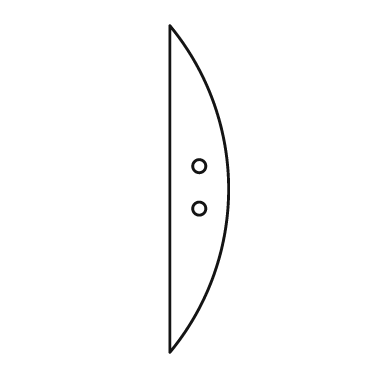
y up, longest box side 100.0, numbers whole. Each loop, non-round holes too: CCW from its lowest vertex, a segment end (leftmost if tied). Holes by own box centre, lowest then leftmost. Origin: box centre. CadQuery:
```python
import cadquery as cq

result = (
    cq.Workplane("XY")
    .moveTo(-9.0, -50.0)
    .threePointArc((9.0, 0.0), (-9.0, 50.0))
    .close()
    .moveTo(0.0, -6.0)
    .circle(2.0)
    .moveTo(0.0, 7.0)
    .circle(2.0)
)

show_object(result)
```